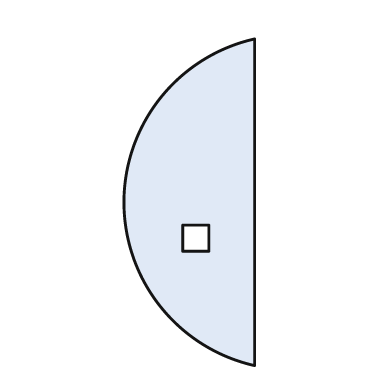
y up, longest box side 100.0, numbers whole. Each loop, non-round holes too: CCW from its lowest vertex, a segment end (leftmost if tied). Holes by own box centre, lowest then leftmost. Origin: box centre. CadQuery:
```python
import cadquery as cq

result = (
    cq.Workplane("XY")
    .moveTo(20.0, -50.0)
    .lineTo(20.0, 50.0)
    .threePointArc((-20.0, 0.0), (20.0, -50.0))
    .close()
    .moveTo(-2.0, -15.0)
    .lineTo(6.0, -15.0)
    .lineTo(6.0, -7.0)
    .lineTo(-2.0, -7.0)
    .close()
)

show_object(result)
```